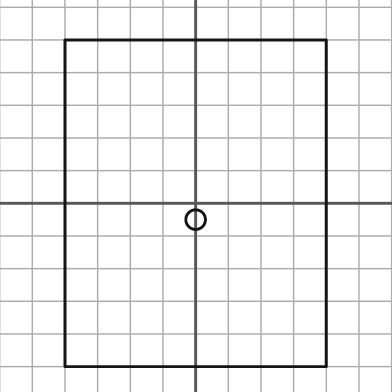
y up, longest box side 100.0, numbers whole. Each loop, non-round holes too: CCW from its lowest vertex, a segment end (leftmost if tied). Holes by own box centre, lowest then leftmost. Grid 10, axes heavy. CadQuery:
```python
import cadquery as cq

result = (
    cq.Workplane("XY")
    .moveTo(-40.0, -50.0)
    .lineTo(40.0, -50.0)
    .lineTo(40.0, 50.0)
    .lineTo(-40.0, 50.0)
    .close()
    .moveTo(0.0, -5.0)
    .circle(3.0)
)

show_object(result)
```